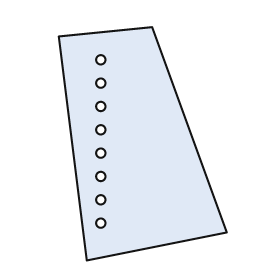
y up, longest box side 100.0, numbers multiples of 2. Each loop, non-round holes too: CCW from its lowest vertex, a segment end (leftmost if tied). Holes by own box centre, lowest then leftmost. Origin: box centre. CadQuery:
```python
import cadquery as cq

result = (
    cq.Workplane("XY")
    .moveTo(-24.0, -50.0)
    .lineTo(36.0, -38.0)
    .lineTo(4.0, 50.0)
    .lineTo(-36.0, 46.0)
    .close()
    .moveTo(-18.0, -34.0)
    .circle(2.0)
    .moveTo(-18.0, -24.0)
    .circle(2.0)
    .moveTo(-18.0, -14.0)
    .circle(2.0)
    .moveTo(-18.0, -4.0)
    .circle(2.0)
    .moveTo(-18.0, 6.0)
    .circle(2.0)
    .moveTo(-18.0, 16.0)
    .circle(2.0)
    .moveTo(-18.0, 26.0)
    .circle(2.0)
    .moveTo(-18.0, 36.0)
    .circle(2.0)
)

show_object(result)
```